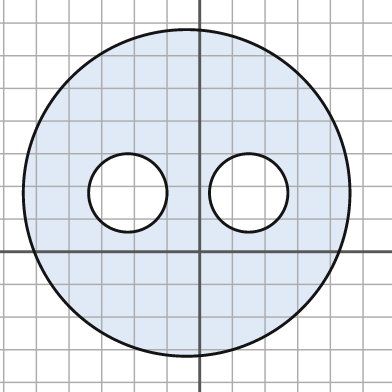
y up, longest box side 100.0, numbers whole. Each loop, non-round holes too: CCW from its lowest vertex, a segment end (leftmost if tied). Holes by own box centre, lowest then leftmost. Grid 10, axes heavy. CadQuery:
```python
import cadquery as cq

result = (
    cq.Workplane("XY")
    .moveTo(-4.0, 18.0)
    .circle(50.0)
    .moveTo(-22.0, 18.0)
    .circle(12.0)
    .moveTo(15.0, 18.0)
    .circle(12.0)
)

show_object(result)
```